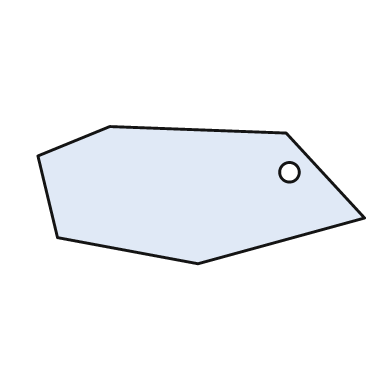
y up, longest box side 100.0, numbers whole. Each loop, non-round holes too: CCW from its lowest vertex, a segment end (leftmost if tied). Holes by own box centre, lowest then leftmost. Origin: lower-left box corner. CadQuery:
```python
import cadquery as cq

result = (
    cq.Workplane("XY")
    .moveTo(49.0, 0.0)
    .lineTo(100.0, 14.0)
    .lineTo(76.0, 40.0)
    .lineTo(22.0, 42.0)
    .lineTo(0.0, 33.0)
    .lineTo(6.0, 8.0)
    .close()
    .moveTo(77.0, 28.0)
    .circle(3.0)
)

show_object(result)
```